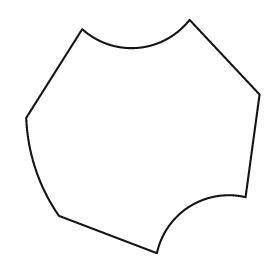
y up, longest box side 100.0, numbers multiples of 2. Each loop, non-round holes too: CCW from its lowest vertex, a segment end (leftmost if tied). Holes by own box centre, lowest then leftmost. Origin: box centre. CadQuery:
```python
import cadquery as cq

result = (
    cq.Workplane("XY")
    .moveTo(6.0, -50.0)
    .threePointArc((20.0, -30.0), (44.0, -26.0))
    .lineTo(50.0, 18.0)
    .lineTo(20.0, 50.0)
    .threePointArc((-2.0, 38.0), (-26.0, 46.0))
    .lineTo(-50.0, 8.0)
    .threePointArc((-46.0, -14.0), (-36.0, -34.0))
    .close()
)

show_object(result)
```